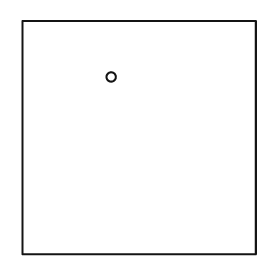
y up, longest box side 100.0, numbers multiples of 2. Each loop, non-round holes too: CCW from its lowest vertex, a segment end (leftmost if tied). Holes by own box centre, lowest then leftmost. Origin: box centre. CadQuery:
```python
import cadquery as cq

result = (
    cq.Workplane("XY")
    .moveTo(-50.0, -50.0)
    .lineTo(50.0, -50.0)
    .lineTo(50.0, 50.0)
    .lineTo(-50.0, 50.0)
    .close()
    .moveTo(-12.0, 26.0)
    .circle(2.0)
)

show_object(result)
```